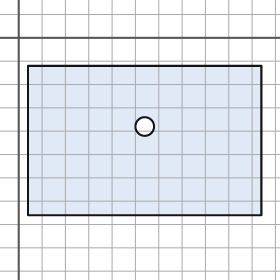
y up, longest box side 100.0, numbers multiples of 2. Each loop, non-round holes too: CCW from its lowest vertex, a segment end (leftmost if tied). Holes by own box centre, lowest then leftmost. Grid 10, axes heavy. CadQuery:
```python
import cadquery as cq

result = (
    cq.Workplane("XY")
    .moveTo(4.0, -76.0)
    .lineTo(104.0, -76.0)
    .lineTo(104.0, -12.0)
    .lineTo(4.0, -12.0)
    .close()
    .moveTo(54.0, -38.0)
    .circle(4.0)
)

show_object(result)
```